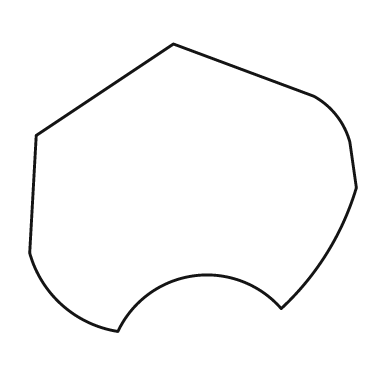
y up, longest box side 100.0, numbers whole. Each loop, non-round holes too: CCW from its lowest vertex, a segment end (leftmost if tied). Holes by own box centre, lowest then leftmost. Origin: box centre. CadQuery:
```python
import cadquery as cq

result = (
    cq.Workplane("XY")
    .moveTo(-23.0, -44.0)
    .threePointArc((0.0, -27.0), (27.0, -37.0))
    .threePointArc((41.0, -20.0), (50.0, 0.0))
    .lineTo(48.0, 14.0)
    .threePointArc((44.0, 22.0), (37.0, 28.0))
    .lineTo(-6.0, 44.0)
    .lineTo(-48.0, 16.0)
    .lineTo(-50.0, -20.0)
    .threePointArc((-40.0, -36.0), (-23.0, -44.0))
    .close()
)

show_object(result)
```